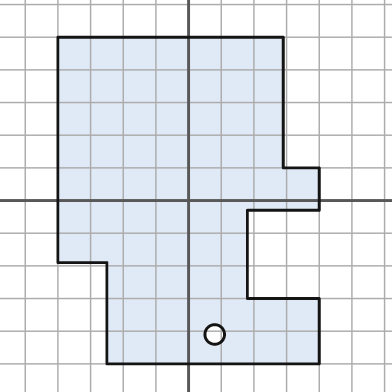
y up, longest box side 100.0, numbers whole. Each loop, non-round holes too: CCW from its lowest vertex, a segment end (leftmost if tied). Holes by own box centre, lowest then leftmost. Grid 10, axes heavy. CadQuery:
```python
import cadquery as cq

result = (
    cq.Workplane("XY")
    .moveTo(-25.0, -50.0)
    .lineTo(40.0, -50.0)
    .lineTo(40.0, -30.0)
    .lineTo(18.0, -30.0)
    .lineTo(18.0, -3.0)
    .lineTo(40.0, -3.0)
    .lineTo(40.0, 10.0)
    .lineTo(29.0, 10.0)
    .lineTo(29.0, 50.0)
    .lineTo(-40.0, 50.0)
    .lineTo(-40.0, -19.0)
    .lineTo(-25.0, -19.0)
    .close()
    .moveTo(8.0, -41.0)
    .circle(3.0)
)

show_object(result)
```